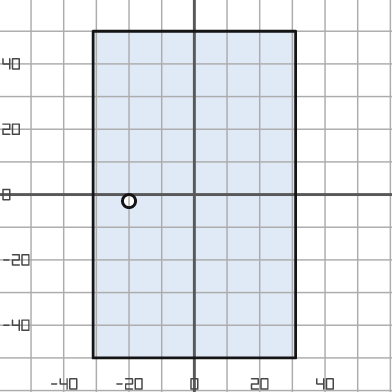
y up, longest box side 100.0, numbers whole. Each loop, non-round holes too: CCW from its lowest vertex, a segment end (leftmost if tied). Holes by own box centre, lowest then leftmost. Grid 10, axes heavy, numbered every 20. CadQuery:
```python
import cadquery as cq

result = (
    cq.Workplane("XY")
    .moveTo(-31.0, -50.0)
    .lineTo(31.0, -50.0)
    .lineTo(31.0, 50.0)
    .lineTo(-31.0, 50.0)
    .close()
    .moveTo(-20.0, -2.0)
    .circle(2.0)
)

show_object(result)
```